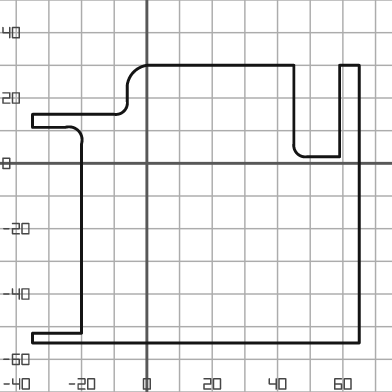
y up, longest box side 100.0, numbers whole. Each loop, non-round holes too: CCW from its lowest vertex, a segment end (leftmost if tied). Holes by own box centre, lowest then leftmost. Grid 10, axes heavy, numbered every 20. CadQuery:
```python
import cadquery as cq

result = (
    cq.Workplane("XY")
    .moveTo(-35.0, -55.0)
    .lineTo(65.0, -55.0)
    .lineTo(65.0, 30.0)
    .lineTo(59.0, 30.0)
    .lineTo(59.0, 2.0)
    .lineTo(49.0, 2.0)
    .threePointArc((46.0, 3.0), (45.0, 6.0))
    .lineTo(45.0, 30.0)
    .lineTo(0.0, 30.0)
    .threePointArc((-4.0, 28.0), (-6.0, 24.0))
    .lineTo(-6.0, 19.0)
    .threePointArc((-7.0, 16.0), (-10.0, 15.0))
    .lineTo(-35.0, 15.0)
    .lineTo(-35.0, 11.0)
    .lineTo(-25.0, 11.0)
    .threePointArc((-21.0, 10.0), (-20.0, 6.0))
    .lineTo(-20.0, -52.0)
    .lineTo(-35.0, -52.0)
    .close()
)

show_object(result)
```